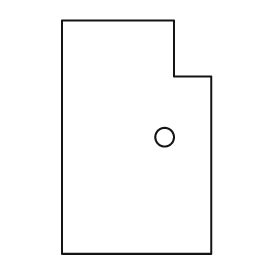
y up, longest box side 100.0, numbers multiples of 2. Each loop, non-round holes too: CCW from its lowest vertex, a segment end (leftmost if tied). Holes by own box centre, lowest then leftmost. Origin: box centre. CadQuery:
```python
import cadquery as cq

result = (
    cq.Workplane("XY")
    .moveTo(-32.0, -50.0)
    .lineTo(32.0, -50.0)
    .lineTo(32.0, 26.0)
    .lineTo(16.0, 26.0)
    .lineTo(16.0, 50.0)
    .lineTo(-32.0, 50.0)
    .close()
    .moveTo(12.0, 0.0)
    .circle(4.0)
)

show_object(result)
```